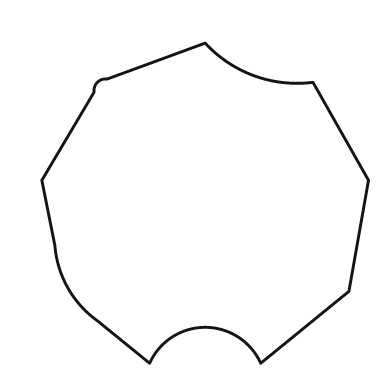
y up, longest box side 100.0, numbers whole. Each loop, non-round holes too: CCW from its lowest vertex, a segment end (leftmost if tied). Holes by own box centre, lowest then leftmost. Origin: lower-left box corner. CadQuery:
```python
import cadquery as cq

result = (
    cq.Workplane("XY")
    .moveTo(33.0, 0.0)
    .threePointArc((50.0, 11.0), (67.0, 0.0))
    .lineTo(94.0, 22.0)
    .lineTo(100.0, 56.0)
    .lineTo(83.0, 86.0)
    .threePointArc((65.0, 88.0), (50.0, 98.0))
    .lineTo(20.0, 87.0)
    .threePointArc((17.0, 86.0), (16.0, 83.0))
    .lineTo(0.0, 56.0)
    .lineTo(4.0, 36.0)
    .threePointArc((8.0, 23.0), (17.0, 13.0))
    .close()
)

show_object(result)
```